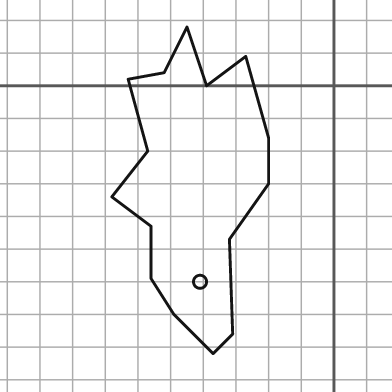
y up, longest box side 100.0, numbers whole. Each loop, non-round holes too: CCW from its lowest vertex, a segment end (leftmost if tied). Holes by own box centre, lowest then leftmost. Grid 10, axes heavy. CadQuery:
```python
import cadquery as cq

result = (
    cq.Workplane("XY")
    .moveTo(-37.0, -82.0)
    .lineTo(-31.0, -76.0)
    .lineTo(-32.0, -47.0)
    .lineTo(-20.0, -30.0)
    .lineTo(-20.0, -16.0)
    .lineTo(-27.0, 9.0)
    .lineTo(-39.0, 0.0)
    .lineTo(-45.0, 18.0)
    .lineTo(-52.0, 4.0)
    .lineTo(-63.0, 2.0)
    .lineTo(-57.0, -20.0)
    .lineTo(-68.0, -34.0)
    .lineTo(-56.0, -43.0)
    .lineTo(-56.0, -59.0)
    .lineTo(-49.0, -70.0)
    .close()
    .moveTo(-41.0, -60.0)
    .circle(2.0)
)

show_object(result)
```